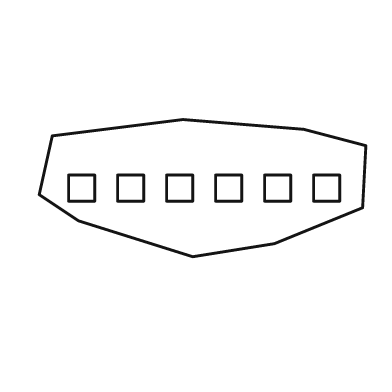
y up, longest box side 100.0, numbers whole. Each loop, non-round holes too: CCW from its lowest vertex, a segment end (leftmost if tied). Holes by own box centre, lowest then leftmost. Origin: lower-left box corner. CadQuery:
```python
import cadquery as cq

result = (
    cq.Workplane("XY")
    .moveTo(47.0, 0.0)
    .lineTo(72.0, 4.0)
    .lineTo(99.0, 15.0)
    .lineTo(100.0, 34.0)
    .lineTo(81.0, 39.0)
    .lineTo(44.0, 42.0)
    .lineTo(4.0, 37.0)
    .lineTo(0.0, 19.0)
    .lineTo(12.0, 11.0)
    .close()
    .moveTo(9.0, 17.0)
    .lineTo(17.0, 17.0)
    .lineTo(17.0, 25.0)
    .lineTo(9.0, 25.0)
    .close()
    .moveTo(24.0, 17.0)
    .lineTo(32.0, 17.0)
    .lineTo(32.0, 25.0)
    .lineTo(24.0, 25.0)
    .close()
    .moveTo(39.0, 17.0)
    .lineTo(47.0, 17.0)
    .lineTo(47.0, 25.0)
    .lineTo(39.0, 25.0)
    .close()
    .moveTo(54.0, 17.0)
    .lineTo(62.0, 17.0)
    .lineTo(62.0, 25.0)
    .lineTo(54.0, 25.0)
    .close()
    .moveTo(69.0, 17.0)
    .lineTo(77.0, 17.0)
    .lineTo(77.0, 25.0)
    .lineTo(69.0, 25.0)
    .close()
    .moveTo(84.0, 17.0)
    .lineTo(92.0, 17.0)
    .lineTo(92.0, 25.0)
    .lineTo(84.0, 25.0)
    .close()
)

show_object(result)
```